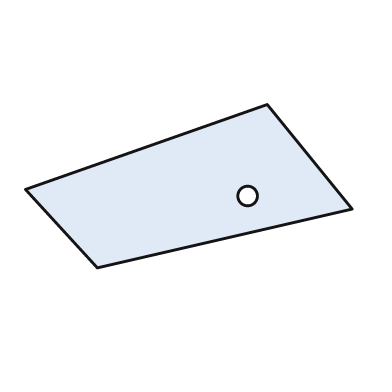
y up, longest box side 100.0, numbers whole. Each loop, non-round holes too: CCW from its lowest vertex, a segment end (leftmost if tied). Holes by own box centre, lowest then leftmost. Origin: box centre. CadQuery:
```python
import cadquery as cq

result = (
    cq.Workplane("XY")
    .moveTo(-28.0, -25.0)
    .lineTo(50.0, -7.0)
    .lineTo(24.0, 25.0)
    .lineTo(-50.0, -1.0)
    .close()
    .moveTo(18.0, -3.0)
    .circle(3.0)
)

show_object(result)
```